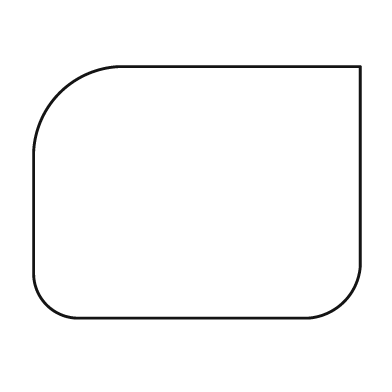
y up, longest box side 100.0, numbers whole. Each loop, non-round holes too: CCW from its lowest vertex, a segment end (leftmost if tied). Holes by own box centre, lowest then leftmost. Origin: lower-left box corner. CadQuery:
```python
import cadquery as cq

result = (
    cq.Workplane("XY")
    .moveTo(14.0, 0.0)
    .lineTo(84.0, 0.0)
    .threePointArc((95.0, 5.0), (100.0, 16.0))
    .lineTo(100.0, 77.0)
    .lineTo(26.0, 77.0)
    .threePointArc((8.0, 69.0), (0.0, 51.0))
    .lineTo(0.0, 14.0)
    .threePointArc((4.0, 4.0), (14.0, 0.0))
    .close()
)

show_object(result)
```